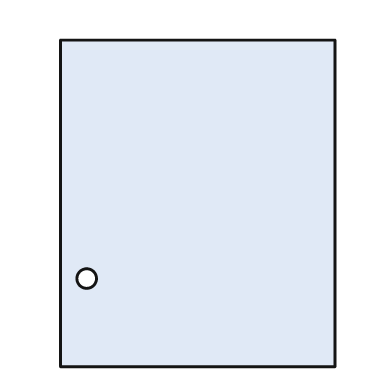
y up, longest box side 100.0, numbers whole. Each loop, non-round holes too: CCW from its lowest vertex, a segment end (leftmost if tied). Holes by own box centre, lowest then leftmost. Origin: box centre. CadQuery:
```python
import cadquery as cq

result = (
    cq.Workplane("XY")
    .moveTo(-42.0, -50.0)
    .lineTo(42.0, -50.0)
    .lineTo(42.0, 50.0)
    .lineTo(-42.0, 50.0)
    .close()
    .moveTo(-34.0, -23.0)
    .circle(3.0)
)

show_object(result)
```